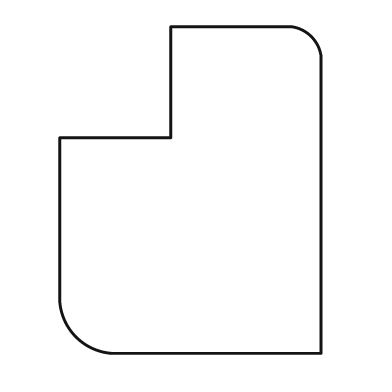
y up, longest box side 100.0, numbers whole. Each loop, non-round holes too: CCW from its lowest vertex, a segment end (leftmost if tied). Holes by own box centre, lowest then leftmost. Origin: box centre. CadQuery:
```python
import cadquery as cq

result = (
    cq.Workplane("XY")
    .moveTo(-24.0, -50.0)
    .lineTo(40.0, -50.0)
    .lineTo(40.0, 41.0)
    .threePointArc((37.0, 47.0), (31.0, 50.0))
    .lineTo(-6.0, 50.0)
    .lineTo(-6.0, 16.0)
    .lineTo(-40.0, 16.0)
    .lineTo(-40.0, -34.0)
    .threePointArc((-35.0, -45.0), (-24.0, -50.0))
    .close()
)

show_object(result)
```